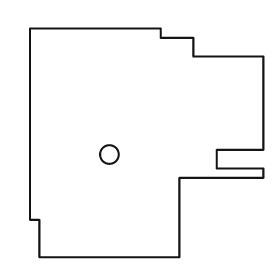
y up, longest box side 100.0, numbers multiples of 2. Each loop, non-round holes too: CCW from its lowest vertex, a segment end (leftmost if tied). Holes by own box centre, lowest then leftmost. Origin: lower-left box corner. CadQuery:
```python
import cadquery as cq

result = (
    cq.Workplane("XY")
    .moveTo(4.0, 0.0)
    .lineTo(64.0, 0.0)
    .lineTo(64.0, 34.0)
    .lineTo(100.0, 34.0)
    .lineTo(100.0, 38.0)
    .lineTo(80.0, 38.0)
    .lineTo(80.0, 46.0)
    .lineTo(100.0, 46.0)
    .lineTo(100.0, 86.0)
    .lineTo(70.0, 86.0)
    .lineTo(70.0, 94.0)
    .lineTo(56.0, 94.0)
    .lineTo(56.0, 98.0)
    .lineTo(0.0, 98.0)
    .lineTo(0.0, 16.0)
    .lineTo(4.0, 16.0)
    .close()
    .moveTo(34.0, 44.0)
    .circle(4.0)
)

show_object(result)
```